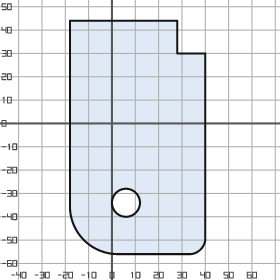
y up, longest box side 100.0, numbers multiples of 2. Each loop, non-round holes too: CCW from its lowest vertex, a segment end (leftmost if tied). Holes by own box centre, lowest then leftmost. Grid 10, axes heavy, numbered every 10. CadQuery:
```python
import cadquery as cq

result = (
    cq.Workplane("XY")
    .moveTo(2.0, -56.0)
    .lineTo(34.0, -56.0)
    .threePointArc((38.0, -54.0), (40.0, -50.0))
    .lineTo(40.0, 30.0)
    .lineTo(28.0, 30.0)
    .lineTo(28.0, 44.0)
    .lineTo(-18.0, 44.0)
    .lineTo(-18.0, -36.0)
    .threePointArc((-12.0, -50.0), (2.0, -56.0))
    .close()
    .moveTo(6.0, -34.0)
    .circle(6.0)
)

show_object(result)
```